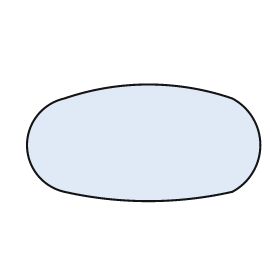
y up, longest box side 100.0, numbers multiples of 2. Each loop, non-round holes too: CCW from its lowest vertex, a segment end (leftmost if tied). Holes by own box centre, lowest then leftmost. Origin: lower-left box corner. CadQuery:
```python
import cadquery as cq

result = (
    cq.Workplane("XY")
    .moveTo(16.0, 4.0)
    .threePointArc((52.0, 0.0), (88.0, 4.0))
    .threePointArc((100.0, 24.0), (88.0, 44.0))
    .threePointArc((52.0, 50.0), (16.0, 44.0))
    .threePointArc((0.0, 24.0), (16.0, 4.0))
    .close()
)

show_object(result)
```